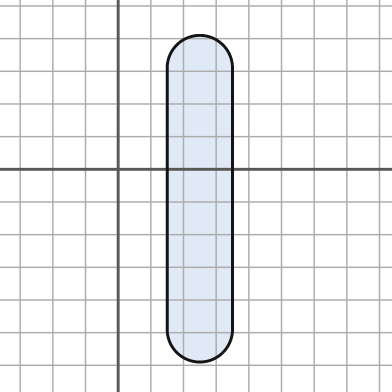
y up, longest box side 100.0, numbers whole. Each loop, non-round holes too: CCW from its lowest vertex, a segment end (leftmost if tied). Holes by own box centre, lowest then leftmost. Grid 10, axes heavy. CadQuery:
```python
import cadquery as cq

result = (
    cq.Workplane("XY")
    .moveTo(15.0, -49.0)
    .threePointArc((25.0, -59.0), (35.0, -49.0))
    .lineTo(35.0, 31.0)
    .threePointArc((25.0, 41.0), (15.0, 31.0))
    .close()
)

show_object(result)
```